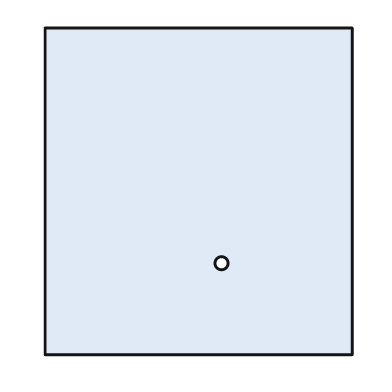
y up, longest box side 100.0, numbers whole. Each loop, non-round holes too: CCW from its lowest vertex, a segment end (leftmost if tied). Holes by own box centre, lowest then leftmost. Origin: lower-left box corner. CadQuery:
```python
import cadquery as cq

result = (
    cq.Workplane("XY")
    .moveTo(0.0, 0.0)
    .lineTo(94.0, 0.0)
    .lineTo(94.0, 100.0)
    .lineTo(0.0, 100.0)
    .close()
    .moveTo(54.0, 28.0)
    .circle(2.0)
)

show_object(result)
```